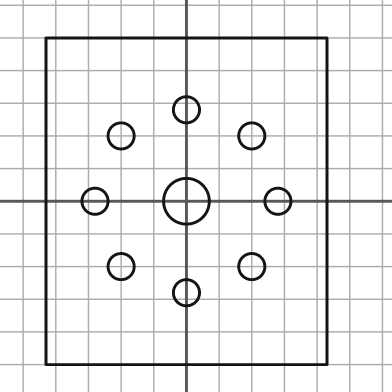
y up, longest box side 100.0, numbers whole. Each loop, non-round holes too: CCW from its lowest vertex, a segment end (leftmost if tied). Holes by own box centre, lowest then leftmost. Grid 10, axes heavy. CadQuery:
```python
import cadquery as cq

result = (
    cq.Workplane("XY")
    .moveTo(-43.0, -50.0)
    .lineTo(43.0, -50.0)
    .lineTo(43.0, 50.0)
    .lineTo(-43.0, 50.0)
    .close()
    .moveTo(0.0, -28.0)
    .circle(4.0)
    .moveTo(-20.0, -20.0)
    .circle(4.0)
    .moveTo(20.0, -20.0)
    .circle(4.0)
    .moveTo(-28.0, 0.0)
    .circle(4.0)
    .moveTo(0.0, 0.0)
    .circle(7.0)
    .moveTo(28.0, 0.0)
    .circle(4.0)
    .moveTo(-20.0, 20.0)
    .circle(4.0)
    .moveTo(20.0, 20.0)
    .circle(4.0)
    .moveTo(0.0, 28.0)
    .circle(4.0)
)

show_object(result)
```